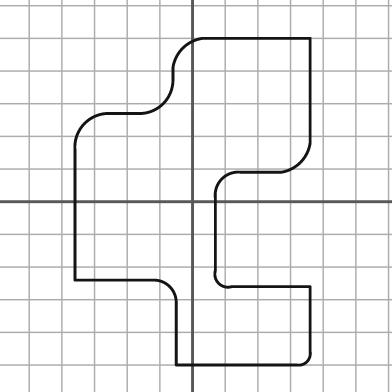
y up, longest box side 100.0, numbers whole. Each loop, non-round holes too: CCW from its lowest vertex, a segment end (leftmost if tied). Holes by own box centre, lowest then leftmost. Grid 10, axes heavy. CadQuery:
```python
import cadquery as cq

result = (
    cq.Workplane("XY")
    .moveTo(-5.0, -50.0)
    .lineTo(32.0, -50.0)
    .threePointArc((35.0, -49.0), (36.0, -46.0))
    .lineTo(36.0, -26.0)
    .lineTo(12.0, -26.0)
    .threePointArc((8.0, -25.0), (7.0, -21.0))
    .lineTo(7.0, 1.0)
    .threePointArc((9.0, 7.0), (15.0, 9.0))
    .lineTo(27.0, 9.0)
    .threePointArc((33.0, 12.0), (36.0, 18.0))
    .lineTo(36.0, 50.0)
    .lineTo(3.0, 50.0)
    .threePointArc((-3.0, 47.0), (-6.0, 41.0))
    .lineTo(-6.0, 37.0)
    .threePointArc((-9.0, 30.0), (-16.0, 27.0))
    .lineTo(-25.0, 27.0)
    .threePointArc((-33.0, 24.0), (-36.0, 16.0))
    .lineTo(-36.0, -24.0)
    .lineTo(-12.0, -24.0)
    .threePointArc((-7.0, -26.0), (-5.0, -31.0))
    .close()
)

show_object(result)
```